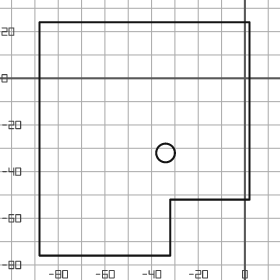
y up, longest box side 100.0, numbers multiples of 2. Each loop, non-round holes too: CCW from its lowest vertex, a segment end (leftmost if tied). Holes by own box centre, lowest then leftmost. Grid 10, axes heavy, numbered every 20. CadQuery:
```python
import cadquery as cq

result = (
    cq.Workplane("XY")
    .moveTo(-88.0, -76.0)
    .lineTo(-32.0, -76.0)
    .lineTo(-32.0, -52.0)
    .lineTo(2.0, -52.0)
    .lineTo(2.0, 24.0)
    .lineTo(-88.0, 24.0)
    .close()
    .moveTo(-34.0, -32.0)
    .circle(4.0)
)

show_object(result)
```